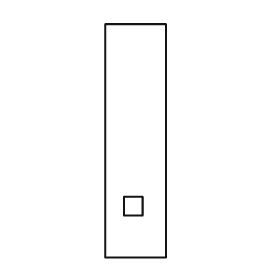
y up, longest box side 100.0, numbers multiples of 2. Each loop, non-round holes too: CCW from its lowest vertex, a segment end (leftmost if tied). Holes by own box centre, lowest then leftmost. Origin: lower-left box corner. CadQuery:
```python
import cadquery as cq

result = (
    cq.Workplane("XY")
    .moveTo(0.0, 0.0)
    .lineTo(26.0, 0.0)
    .lineTo(26.0, 100.0)
    .lineTo(0.0, 100.0)
    .close()
    .moveTo(8.0, 18.0)
    .lineTo(16.0, 18.0)
    .lineTo(16.0, 26.0)
    .lineTo(8.0, 26.0)
    .close()
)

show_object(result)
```